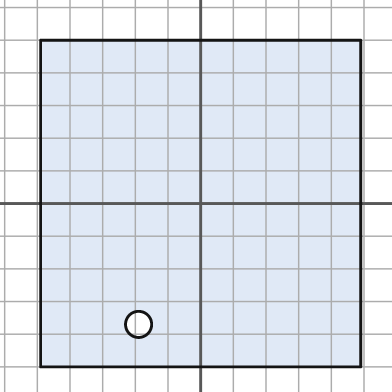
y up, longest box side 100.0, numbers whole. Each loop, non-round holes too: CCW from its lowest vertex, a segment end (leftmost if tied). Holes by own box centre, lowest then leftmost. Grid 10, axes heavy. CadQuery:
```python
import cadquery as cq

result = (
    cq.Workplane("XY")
    .moveTo(-49.0, -50.0)
    .lineTo(49.0, -50.0)
    .lineTo(49.0, 50.0)
    .lineTo(-49.0, 50.0)
    .close()
    .moveTo(-19.0, -37.0)
    .circle(4.0)
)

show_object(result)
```